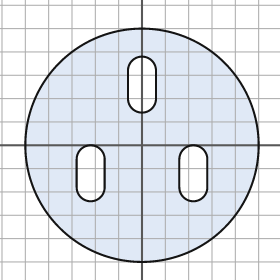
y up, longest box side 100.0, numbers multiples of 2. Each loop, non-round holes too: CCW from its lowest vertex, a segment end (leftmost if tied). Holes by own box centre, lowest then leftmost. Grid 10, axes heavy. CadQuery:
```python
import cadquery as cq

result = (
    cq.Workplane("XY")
    .moveTo(0.0, 0.0)
    .circle(50.0)
    .moveTo(-28.0, -18.0)
    .threePointArc((-22.0, -24.0), (-16.0, -18.0))
    .lineTo(-16.0, -6.0)
    .threePointArc((-22.0, 0.0), (-28.0, -6.0))
    .close()
    .moveTo(16.0, -18.0)
    .threePointArc((22.0, -24.0), (28.0, -18.0))
    .lineTo(28.0, -6.0)
    .threePointArc((22.0, 0.0), (16.0, -6.0))
    .close()
    .moveTo(-6.0, 20.0)
    .threePointArc((0.0, 14.0), (6.0, 20.0))
    .lineTo(6.0, 32.0)
    .threePointArc((0.0, 38.0), (-6.0, 32.0))
    .close()
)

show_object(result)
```